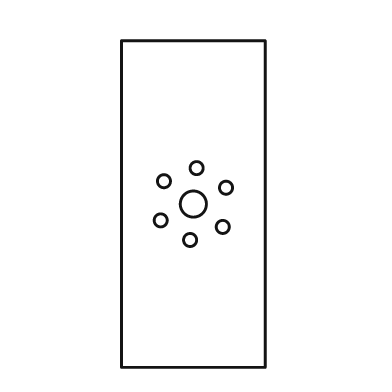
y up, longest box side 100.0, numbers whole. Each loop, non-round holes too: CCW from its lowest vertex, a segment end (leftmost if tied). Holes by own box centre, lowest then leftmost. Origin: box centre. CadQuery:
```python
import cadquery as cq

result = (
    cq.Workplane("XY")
    .moveTo(-22.0, -50.0)
    .lineTo(22.0, -50.0)
    .lineTo(22.0, 50.0)
    .lineTo(-22.0, 50.0)
    .close()
    .moveTo(-1.0, -11.0)
    .circle(2.0)
    .moveTo(9.0, -7.0)
    .circle(2.0)
    .moveTo(-10.0, -5.0)
    .circle(2.0)
    .moveTo(0.0, 0.0)
    .circle(4.0)
    .moveTo(10.0, 5.0)
    .circle(2.0)
    .moveTo(-9.0, 7.0)
    .circle(2.0)
    .moveTo(1.0, 11.0)
    .circle(2.0)
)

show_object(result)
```